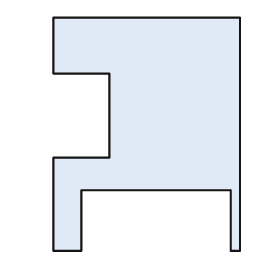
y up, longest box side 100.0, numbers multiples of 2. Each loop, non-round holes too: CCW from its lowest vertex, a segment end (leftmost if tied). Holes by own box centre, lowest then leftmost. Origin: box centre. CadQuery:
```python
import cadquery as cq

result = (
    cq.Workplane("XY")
    .moveTo(-40.0, -50.0)
    .lineTo(-28.0, -50.0)
    .lineTo(-28.0, -24.0)
    .lineTo(36.0, -24.0)
    .lineTo(36.0, -50.0)
    .lineTo(40.0, -50.0)
    .lineTo(40.0, 50.0)
    .lineTo(-40.0, 50.0)
    .lineTo(-40.0, 26.0)
    .lineTo(-16.0, 26.0)
    .lineTo(-16.0, -10.0)
    .lineTo(-40.0, -10.0)
    .close()
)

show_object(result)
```